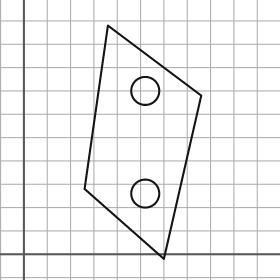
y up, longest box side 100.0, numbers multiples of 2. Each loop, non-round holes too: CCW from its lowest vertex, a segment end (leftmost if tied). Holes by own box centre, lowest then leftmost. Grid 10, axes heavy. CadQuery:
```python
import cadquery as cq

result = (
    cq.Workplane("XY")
    .moveTo(60.0, -2.0)
    .lineTo(76.0, 68.0)
    .lineTo(36.0, 98.0)
    .lineTo(26.0, 28.0)
    .close()
    .moveTo(52.0, 26.0)
    .circle(6.0)
    .moveTo(52.0, 70.0)
    .circle(6.0)
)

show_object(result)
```